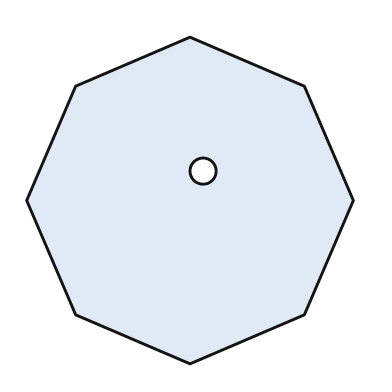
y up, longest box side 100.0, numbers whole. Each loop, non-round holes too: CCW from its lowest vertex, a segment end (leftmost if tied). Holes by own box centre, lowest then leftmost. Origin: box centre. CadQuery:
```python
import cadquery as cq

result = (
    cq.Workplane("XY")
    .moveTo(0.0, -50.0)
    .lineTo(35.0, -35.0)
    .lineTo(50.0, 0.0)
    .lineTo(35.0, 35.0)
    .lineTo(0.0, 50.0)
    .lineTo(-35.0, 35.0)
    .lineTo(-50.0, 0.0)
    .lineTo(-35.0, -35.0)
    .close()
    .moveTo(4.0, 9.0)
    .circle(4.0)
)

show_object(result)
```